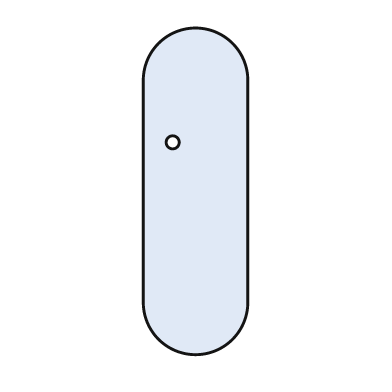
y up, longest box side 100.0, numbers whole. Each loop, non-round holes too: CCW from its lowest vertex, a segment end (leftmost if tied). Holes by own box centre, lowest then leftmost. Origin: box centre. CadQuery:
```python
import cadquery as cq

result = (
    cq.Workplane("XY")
    .moveTo(-16.0, -34.0)
    .threePointArc((0.0, -50.0), (16.0, -34.0))
    .lineTo(16.0, 34.0)
    .threePointArc((0.0, 50.0), (-16.0, 34.0))
    .close()
    .moveTo(-7.0, 15.0)
    .circle(2.0)
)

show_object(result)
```